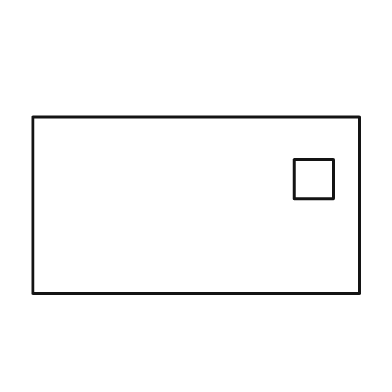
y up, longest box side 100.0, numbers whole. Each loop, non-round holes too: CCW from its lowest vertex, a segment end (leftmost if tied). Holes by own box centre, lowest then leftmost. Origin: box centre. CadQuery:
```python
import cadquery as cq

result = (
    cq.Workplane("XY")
    .moveTo(-50.0, -27.0)
    .lineTo(50.0, -27.0)
    .lineTo(50.0, 27.0)
    .lineTo(-50.0, 27.0)
    .close()
    .moveTo(30.0, 2.0)
    .lineTo(42.0, 2.0)
    .lineTo(42.0, 14.0)
    .lineTo(30.0, 14.0)
    .close()
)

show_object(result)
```